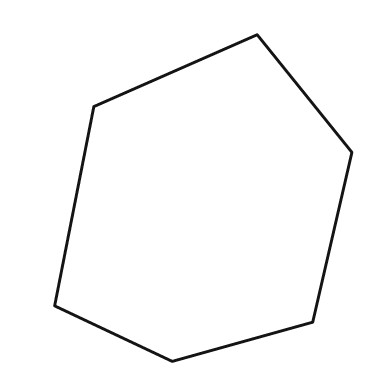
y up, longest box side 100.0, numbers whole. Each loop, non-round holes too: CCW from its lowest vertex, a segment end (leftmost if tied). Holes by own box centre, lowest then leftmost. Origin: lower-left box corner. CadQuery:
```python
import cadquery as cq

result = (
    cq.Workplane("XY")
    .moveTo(36.0, 0.0)
    .lineTo(79.0, 12.0)
    .lineTo(91.0, 64.0)
    .lineTo(62.0, 100.0)
    .lineTo(12.0, 78.0)
    .lineTo(0.0, 17.0)
    .close()
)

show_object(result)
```